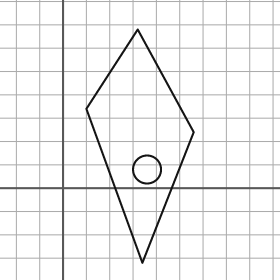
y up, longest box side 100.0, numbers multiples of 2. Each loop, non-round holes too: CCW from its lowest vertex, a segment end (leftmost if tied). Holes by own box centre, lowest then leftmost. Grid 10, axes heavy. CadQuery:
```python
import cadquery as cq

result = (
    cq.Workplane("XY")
    .moveTo(34.0, -32.0)
    .lineTo(56.0, 24.0)
    .lineTo(32.0, 68.0)
    .lineTo(10.0, 34.0)
    .close()
    .moveTo(36.0, 8.0)
    .circle(6.0)
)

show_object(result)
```